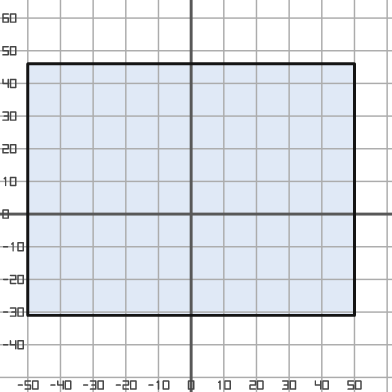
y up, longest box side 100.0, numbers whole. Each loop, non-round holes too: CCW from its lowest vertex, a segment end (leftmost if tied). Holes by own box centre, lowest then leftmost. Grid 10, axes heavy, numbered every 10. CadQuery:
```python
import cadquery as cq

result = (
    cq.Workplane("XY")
    .moveTo(-50.0, -31.0)
    .lineTo(50.0, -31.0)
    .lineTo(50.0, 46.0)
    .lineTo(-50.0, 46.0)
    .close()
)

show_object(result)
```